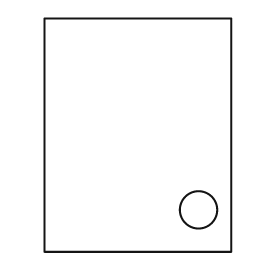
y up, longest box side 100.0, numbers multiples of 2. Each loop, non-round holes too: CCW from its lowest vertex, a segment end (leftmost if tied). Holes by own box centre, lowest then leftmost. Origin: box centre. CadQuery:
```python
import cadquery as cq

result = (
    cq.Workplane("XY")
    .moveTo(-40.0, -50.0)
    .lineTo(40.0, -50.0)
    .lineTo(40.0, 50.0)
    .lineTo(-40.0, 50.0)
    .close()
    .moveTo(26.0, -32.0)
    .circle(8.0)
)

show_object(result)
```